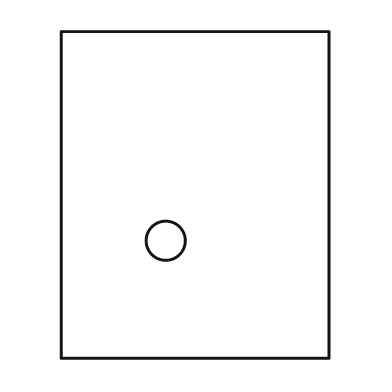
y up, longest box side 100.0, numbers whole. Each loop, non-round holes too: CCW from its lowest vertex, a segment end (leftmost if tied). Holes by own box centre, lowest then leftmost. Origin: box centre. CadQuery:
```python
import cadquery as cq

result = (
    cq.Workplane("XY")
    .moveTo(-41.0, -50.0)
    .lineTo(41.0, -50.0)
    .lineTo(41.0, 50.0)
    .lineTo(-41.0, 50.0)
    .close()
    .moveTo(-9.0, -14.0)
    .circle(6.0)
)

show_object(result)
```